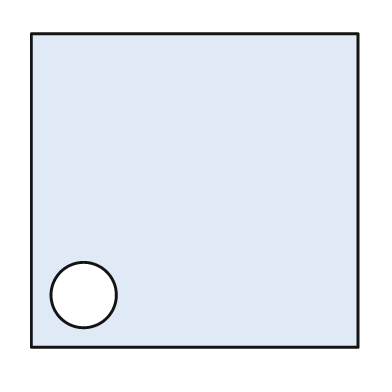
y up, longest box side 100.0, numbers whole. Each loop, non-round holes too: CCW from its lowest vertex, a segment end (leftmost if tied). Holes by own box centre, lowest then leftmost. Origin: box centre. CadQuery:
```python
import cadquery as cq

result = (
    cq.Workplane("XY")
    .moveTo(-50.0, -48.0)
    .lineTo(50.0, -48.0)
    .lineTo(50.0, 48.0)
    .lineTo(-50.0, 48.0)
    .close()
    .moveTo(-34.0, -32.0)
    .circle(10.0)
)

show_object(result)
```